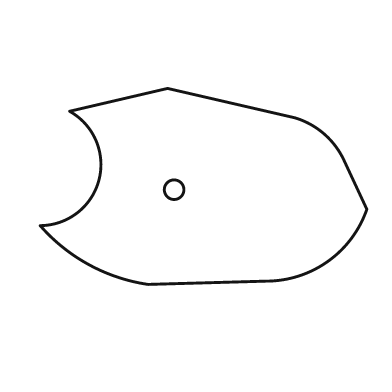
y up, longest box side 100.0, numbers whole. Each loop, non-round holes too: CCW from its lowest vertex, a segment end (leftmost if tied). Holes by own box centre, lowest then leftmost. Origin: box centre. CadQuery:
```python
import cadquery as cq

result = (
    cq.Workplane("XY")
    .moveTo(-17.0, -30.0)
    .lineTo(19.0, -29.0)
    .threePointArc((38.0, -23.0), (50.0, -7.0))
    .lineTo(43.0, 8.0)
    .threePointArc((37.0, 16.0), (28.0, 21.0))
    .lineTo(-11.0, 30.0)
    .lineTo(-41.0, 23.0)
    .threePointArc((-32.0, 2.0), (-50.0, -12.0))
    .threePointArc((-35.0, -24.0), (-17.0, -30.0))
    .close()
    .moveTo(-9.0, -1.0)
    .circle(3.0)
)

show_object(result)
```